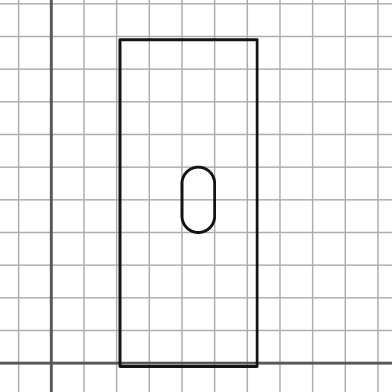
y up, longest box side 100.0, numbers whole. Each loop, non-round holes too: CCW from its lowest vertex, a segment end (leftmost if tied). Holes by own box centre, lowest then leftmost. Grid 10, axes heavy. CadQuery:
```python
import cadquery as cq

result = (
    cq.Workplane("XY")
    .moveTo(21.0, -1.0)
    .lineTo(63.0, -1.0)
    .lineTo(63.0, 99.0)
    .lineTo(21.0, 99.0)
    .close()
    .moveTo(40.0, 45.0)
    .threePointArc((45.0, 40.0), (50.0, 45.0))
    .lineTo(50.0, 55.0)
    .threePointArc((45.0, 60.0), (40.0, 55.0))
    .close()
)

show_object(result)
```